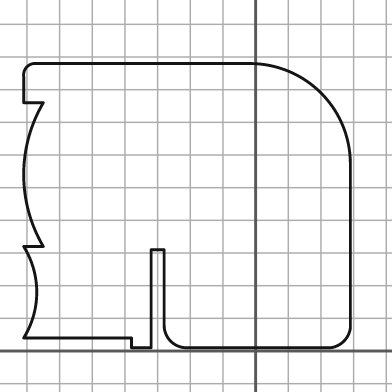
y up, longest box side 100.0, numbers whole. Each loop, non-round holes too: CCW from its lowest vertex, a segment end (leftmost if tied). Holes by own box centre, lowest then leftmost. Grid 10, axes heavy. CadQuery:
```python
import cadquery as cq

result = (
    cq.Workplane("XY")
    .moveTo(-38.0, 1.0)
    .lineTo(-32.0, 1.0)
    .lineTo(-32.0, 31.0)
    .lineTo(-28.0, 31.0)
    .lineTo(-28.0, 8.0)
    .threePointArc((-26.0, 3.0), (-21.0, 1.0))
    .lineTo(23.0, 1.0)
    .threePointArc((27.0, 3.0), (29.0, 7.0))
    .lineTo(29.0, 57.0)
    .threePointArc((20.0, 79.0), (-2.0, 88.0))
    .lineTo(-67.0, 88.0)
    .threePointArc((-70.0, 87.0), (-71.0, 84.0))
    .lineTo(-71.0, 76.0)
    .lineTo(-65.0, 76.0)
    .threePointArc((-71.0, 54.0), (-65.0, 32.0))
    .lineTo(-71.0, 32.0)
    .threePointArc((-67.0, 18.0), (-71.0, 4.0))
    .lineTo(-38.0, 4.0)
    .close()
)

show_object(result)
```